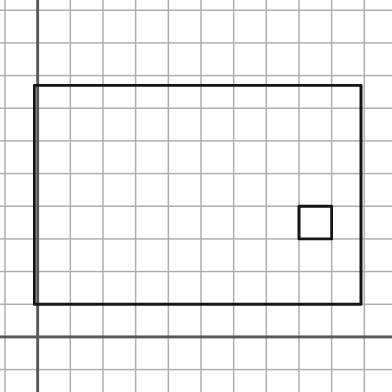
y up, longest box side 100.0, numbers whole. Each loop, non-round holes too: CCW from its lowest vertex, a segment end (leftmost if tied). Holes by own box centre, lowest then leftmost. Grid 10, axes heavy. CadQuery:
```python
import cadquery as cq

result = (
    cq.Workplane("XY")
    .moveTo(-1.0, 10.0)
    .lineTo(99.0, 10.0)
    .lineTo(99.0, 77.0)
    .lineTo(-1.0, 77.0)
    .close()
    .moveTo(80.0, 30.0)
    .lineTo(90.0, 30.0)
    .lineTo(90.0, 40.0)
    .lineTo(80.0, 40.0)
    .close()
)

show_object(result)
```